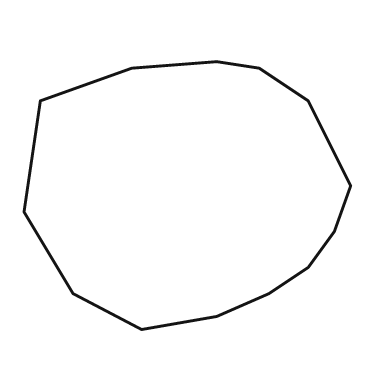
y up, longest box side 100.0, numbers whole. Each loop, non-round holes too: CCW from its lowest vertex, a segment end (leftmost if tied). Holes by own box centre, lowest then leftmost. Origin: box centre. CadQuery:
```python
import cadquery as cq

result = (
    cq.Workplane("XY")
    .moveTo(-14.0, -41.0)
    .lineTo(9.0, -37.0)
    .lineTo(25.0, -30.0)
    .lineTo(37.0, -22.0)
    .lineTo(45.0, -11.0)
    .lineTo(50.0, 3.0)
    .lineTo(37.0, 29.0)
    .lineTo(22.0, 39.0)
    .lineTo(9.0, 41.0)
    .lineTo(-17.0, 39.0)
    .lineTo(-45.0, 29.0)
    .lineTo(-50.0, -5.0)
    .lineTo(-35.0, -30.0)
    .close()
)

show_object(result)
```